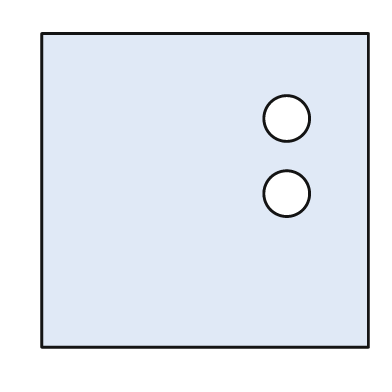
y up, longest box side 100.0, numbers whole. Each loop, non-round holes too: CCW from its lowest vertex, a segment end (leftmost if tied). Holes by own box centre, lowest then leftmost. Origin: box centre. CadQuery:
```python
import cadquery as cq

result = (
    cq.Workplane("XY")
    .moveTo(-50.0, -48.0)
    .lineTo(50.0, -48.0)
    .lineTo(50.0, 48.0)
    .lineTo(-50.0, 48.0)
    .close()
    .moveTo(25.0, -1.0)
    .circle(7.0)
    .moveTo(25.0, 22.0)
    .circle(7.0)
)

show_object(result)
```